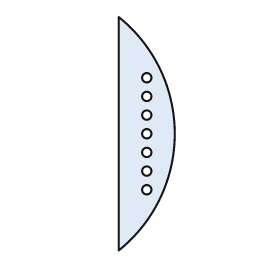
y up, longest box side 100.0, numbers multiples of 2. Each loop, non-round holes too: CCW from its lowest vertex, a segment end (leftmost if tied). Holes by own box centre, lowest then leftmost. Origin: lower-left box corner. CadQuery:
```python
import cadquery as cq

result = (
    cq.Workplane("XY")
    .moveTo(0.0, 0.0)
    .threePointArc((24.0, 50.0), (0.0, 100.0))
    .close()
    .moveTo(12.0, 26.0)
    .circle(2.0)
    .moveTo(12.0, 34.0)
    .circle(2.0)
    .moveTo(12.0, 42.0)
    .circle(2.0)
    .moveTo(12.0, 50.0)
    .circle(2.0)
    .moveTo(12.0, 58.0)
    .circle(2.0)
    .moveTo(12.0, 66.0)
    .circle(2.0)
    .moveTo(12.0, 74.0)
    .circle(2.0)
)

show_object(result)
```